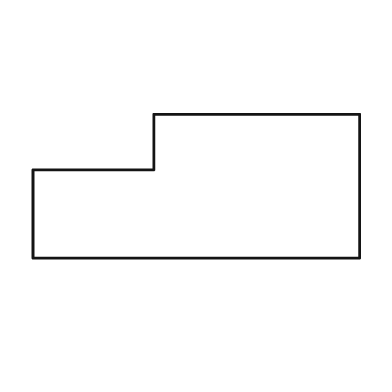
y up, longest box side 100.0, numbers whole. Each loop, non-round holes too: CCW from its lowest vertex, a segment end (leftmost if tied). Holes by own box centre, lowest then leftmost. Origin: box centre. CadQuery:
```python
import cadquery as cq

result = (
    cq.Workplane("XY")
    .moveTo(-50.0, -22.0)
    .lineTo(50.0, -22.0)
    .lineTo(50.0, 22.0)
    .lineTo(-13.0, 22.0)
    .lineTo(-13.0, 5.0)
    .lineTo(-50.0, 5.0)
    .close()
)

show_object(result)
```